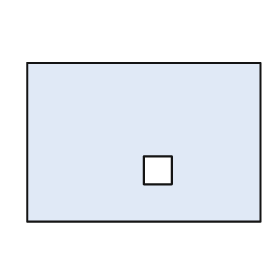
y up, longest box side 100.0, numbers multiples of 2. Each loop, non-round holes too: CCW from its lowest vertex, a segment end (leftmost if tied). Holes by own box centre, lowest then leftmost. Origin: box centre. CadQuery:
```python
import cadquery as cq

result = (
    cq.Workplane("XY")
    .moveTo(-50.0, -34.0)
    .lineTo(50.0, -34.0)
    .lineTo(50.0, 34.0)
    .lineTo(-50.0, 34.0)
    .close()
    .moveTo(0.0, -18.0)
    .lineTo(12.0, -18.0)
    .lineTo(12.0, -6.0)
    .lineTo(0.0, -6.0)
    .close()
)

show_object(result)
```